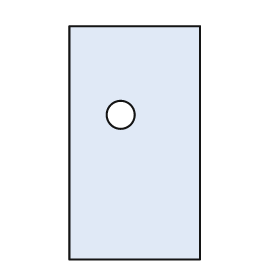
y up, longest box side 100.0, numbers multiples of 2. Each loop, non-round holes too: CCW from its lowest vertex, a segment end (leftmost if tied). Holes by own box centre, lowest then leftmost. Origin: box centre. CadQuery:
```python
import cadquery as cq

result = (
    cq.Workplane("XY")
    .moveTo(-28.0, -50.0)
    .lineTo(28.0, -50.0)
    .lineTo(28.0, 50.0)
    .lineTo(-28.0, 50.0)
    .close()
    .moveTo(-6.0, 12.0)
    .circle(6.0)
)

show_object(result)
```